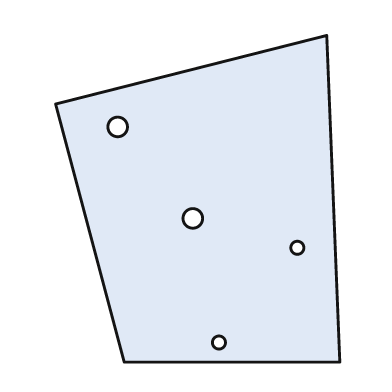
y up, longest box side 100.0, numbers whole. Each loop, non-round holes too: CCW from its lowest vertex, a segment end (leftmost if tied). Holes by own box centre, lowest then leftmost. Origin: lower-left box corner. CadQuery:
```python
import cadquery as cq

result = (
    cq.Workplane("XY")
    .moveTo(21.0, 0.0)
    .lineTo(87.0, 0.0)
    .lineTo(83.0, 100.0)
    .lineTo(0.0, 79.0)
    .close()
    .moveTo(50.0, 6.0)
    .circle(2.0)
    .moveTo(74.0, 35.0)
    .circle(2.0)
    .moveTo(42.0, 44.0)
    .circle(3.0)
    .moveTo(19.0, 72.0)
    .circle(3.0)
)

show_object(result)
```